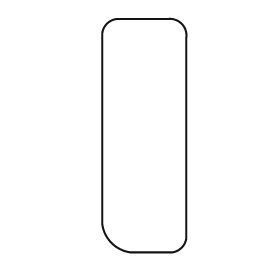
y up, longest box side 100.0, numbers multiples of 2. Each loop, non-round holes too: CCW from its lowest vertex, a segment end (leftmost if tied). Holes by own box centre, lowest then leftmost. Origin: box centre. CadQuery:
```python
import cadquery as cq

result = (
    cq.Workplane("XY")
    .moveTo(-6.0, -50.0)
    .lineTo(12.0, -50.0)
    .threePointArc((16.0, -48.0), (18.0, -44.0))
    .lineTo(18.0, 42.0)
    .threePointArc((16.0, 48.0), (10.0, 50.0))
    .lineTo(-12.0, 50.0)
    .threePointArc((-16.0, 48.0), (-18.0, 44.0))
    .lineTo(-18.0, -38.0)
    .threePointArc((-14.0, -46.0), (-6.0, -50.0))
    .close()
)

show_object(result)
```